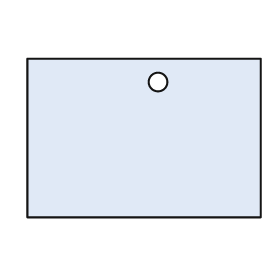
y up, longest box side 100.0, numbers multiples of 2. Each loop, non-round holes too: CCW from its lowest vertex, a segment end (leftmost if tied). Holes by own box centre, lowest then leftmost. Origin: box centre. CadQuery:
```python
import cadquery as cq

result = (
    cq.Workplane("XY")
    .moveTo(-50.0, -34.0)
    .lineTo(50.0, -34.0)
    .lineTo(50.0, 34.0)
    .lineTo(-50.0, 34.0)
    .close()
    .moveTo(6.0, 24.0)
    .circle(4.0)
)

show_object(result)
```